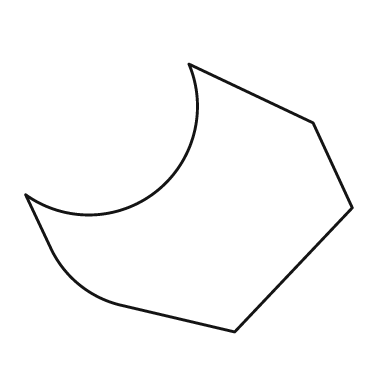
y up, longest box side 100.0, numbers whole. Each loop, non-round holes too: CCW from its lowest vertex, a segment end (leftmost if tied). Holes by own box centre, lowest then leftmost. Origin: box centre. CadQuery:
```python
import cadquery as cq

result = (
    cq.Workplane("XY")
    .moveTo(14.0, -41.0)
    .lineTo(50.0, -3.0)
    .lineTo(38.0, 23.0)
    .lineTo(0.0, 41.0)
    .threePointArc((-10.0, 2.0), (-50.0, 1.0))
    .lineTo(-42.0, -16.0)
    .threePointArc((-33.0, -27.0), (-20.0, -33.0))
    .close()
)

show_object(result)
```